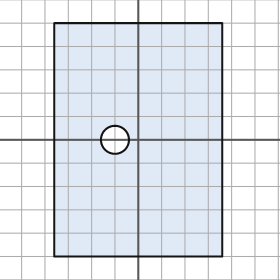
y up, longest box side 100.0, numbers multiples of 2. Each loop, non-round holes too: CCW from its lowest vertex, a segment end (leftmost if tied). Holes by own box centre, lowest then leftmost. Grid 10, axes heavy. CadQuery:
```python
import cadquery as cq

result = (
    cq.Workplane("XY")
    .moveTo(-36.0, -50.0)
    .lineTo(36.0, -50.0)
    .lineTo(36.0, 50.0)
    .lineTo(-36.0, 50.0)
    .close()
    .moveTo(-10.0, 0.0)
    .circle(6.0)
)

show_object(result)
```